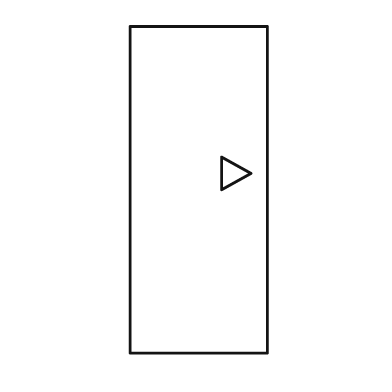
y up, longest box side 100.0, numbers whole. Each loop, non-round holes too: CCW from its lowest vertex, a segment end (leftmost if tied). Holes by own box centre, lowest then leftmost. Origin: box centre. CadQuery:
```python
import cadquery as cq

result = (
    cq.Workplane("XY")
    .moveTo(-21.0, -50.0)
    .lineTo(21.0, -50.0)
    .lineTo(21.0, 50.0)
    .lineTo(-21.0, 50.0)
    .close()
    .moveTo(7.0, 0.0)
    .lineTo(16.0, 5.0)
    .lineTo(7.0, 10.0)
    .close()
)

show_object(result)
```